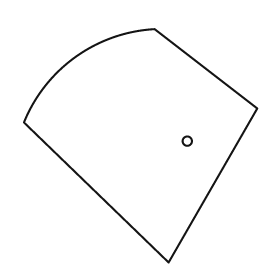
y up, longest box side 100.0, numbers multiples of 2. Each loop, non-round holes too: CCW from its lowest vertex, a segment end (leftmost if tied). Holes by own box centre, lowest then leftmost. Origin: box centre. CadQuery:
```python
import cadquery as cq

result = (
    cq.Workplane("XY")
    .moveTo(12.0, -50.0)
    .lineTo(50.0, 16.0)
    .lineTo(6.0, 50.0)
    .threePointArc((-28.0, 38.0), (-50.0, 10.0))
    .close()
    .moveTo(20.0, 2.0)
    .circle(2.0)
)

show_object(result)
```